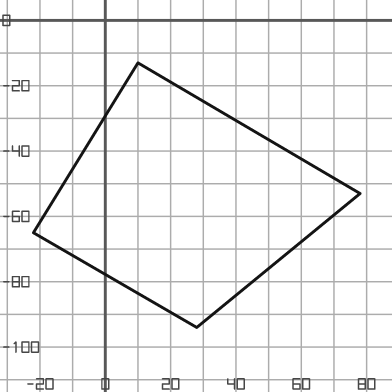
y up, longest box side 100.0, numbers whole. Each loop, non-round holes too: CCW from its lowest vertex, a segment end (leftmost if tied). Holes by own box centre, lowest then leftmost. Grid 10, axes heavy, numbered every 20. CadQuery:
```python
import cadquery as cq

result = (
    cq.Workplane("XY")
    .moveTo(28.0, -94.0)
    .lineTo(78.0, -53.0)
    .lineTo(10.0, -13.0)
    .lineTo(-22.0, -65.0)
    .close()
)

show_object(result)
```